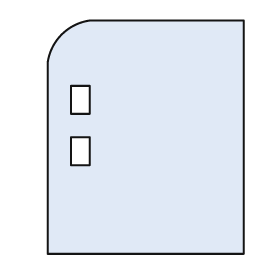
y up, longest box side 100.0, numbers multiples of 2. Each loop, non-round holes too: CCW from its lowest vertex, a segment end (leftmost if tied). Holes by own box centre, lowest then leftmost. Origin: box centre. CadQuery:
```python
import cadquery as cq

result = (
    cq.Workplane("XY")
    .moveTo(-42.0, -50.0)
    .lineTo(42.0, -50.0)
    .lineTo(42.0, 50.0)
    .lineTo(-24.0, 50.0)
    .threePointArc((-36.0, 44.0), (-42.0, 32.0))
    .close()
    .moveTo(-32.0, -12.0)
    .lineTo(-24.0, -12.0)
    .lineTo(-24.0, 0.0)
    .lineTo(-32.0, 0.0)
    .close()
    .moveTo(-32.0, 10.0)
    .lineTo(-24.0, 10.0)
    .lineTo(-24.0, 22.0)
    .lineTo(-32.0, 22.0)
    .close()
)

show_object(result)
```